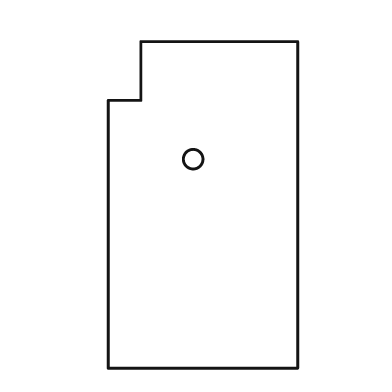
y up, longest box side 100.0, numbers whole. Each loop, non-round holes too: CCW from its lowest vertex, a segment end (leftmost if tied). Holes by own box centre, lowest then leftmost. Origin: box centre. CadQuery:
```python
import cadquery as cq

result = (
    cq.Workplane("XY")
    .moveTo(-29.0, -50.0)
    .lineTo(29.0, -50.0)
    .lineTo(29.0, 50.0)
    .lineTo(-19.0, 50.0)
    .lineTo(-19.0, 32.0)
    .lineTo(-29.0, 32.0)
    .close()
    .moveTo(-3.0, 14.0)
    .circle(3.0)
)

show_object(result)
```